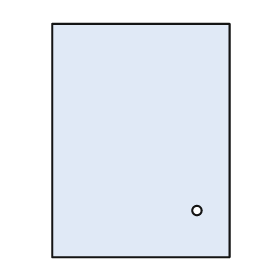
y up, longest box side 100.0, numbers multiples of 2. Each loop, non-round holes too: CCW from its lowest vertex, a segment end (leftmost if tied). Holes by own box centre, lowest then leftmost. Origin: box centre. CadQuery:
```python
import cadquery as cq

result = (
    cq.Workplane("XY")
    .moveTo(-38.0, -50.0)
    .lineTo(38.0, -50.0)
    .lineTo(38.0, 50.0)
    .lineTo(-38.0, 50.0)
    .close()
    .moveTo(24.0, -30.0)
    .circle(2.0)
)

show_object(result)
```